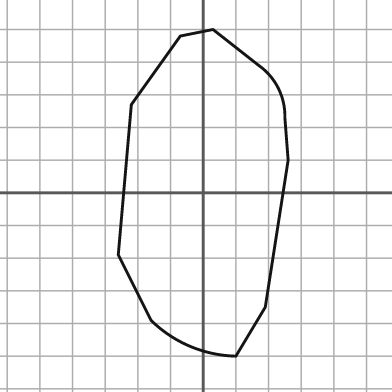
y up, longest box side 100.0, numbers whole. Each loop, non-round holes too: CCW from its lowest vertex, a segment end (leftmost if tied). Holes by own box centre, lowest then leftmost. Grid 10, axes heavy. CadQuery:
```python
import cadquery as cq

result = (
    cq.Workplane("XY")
    .moveTo(10.0, -50.0)
    .lineTo(19.0, -35.0)
    .lineTo(26.0, 10.0)
    .lineTo(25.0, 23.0)
    .threePointArc((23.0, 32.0), (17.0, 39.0))
    .lineTo(3.0, 50.0)
    .lineTo(-7.0, 48.0)
    .lineTo(-22.0, 27.0)
    .lineTo(-26.0, -19.0)
    .lineTo(-16.0, -39.0)
    .threePointArc((-4.0, -47.0), (10.0, -50.0))
    .close()
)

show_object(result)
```